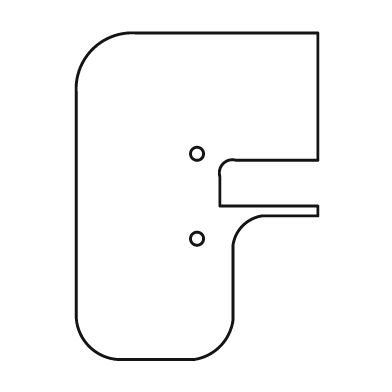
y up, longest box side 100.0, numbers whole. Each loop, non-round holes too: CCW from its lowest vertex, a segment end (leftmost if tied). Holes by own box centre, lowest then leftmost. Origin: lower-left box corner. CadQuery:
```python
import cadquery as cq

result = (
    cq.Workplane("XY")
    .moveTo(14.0, 0.0)
    .lineTo(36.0, 0.0)
    .threePointArc((44.0, 4.0), (48.0, 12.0))
    .lineTo(48.0, 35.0)
    .threePointArc((51.0, 41.0), (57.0, 44.0))
    .lineTo(74.0, 44.0)
    .lineTo(74.0, 47.0)
    .lineTo(44.0, 47.0)
    .lineTo(44.0, 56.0)
    .threePointArc((45.0, 60.0), (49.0, 61.0))
    .lineTo(74.0, 61.0)
    .lineTo(74.0, 100.0)
    .lineTo(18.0, 100.0)
    .threePointArc((5.0, 95.0), (0.0, 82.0))
    .lineTo(0.0, 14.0)
    .threePointArc((4.0, 4.0), (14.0, 0.0))
    .close()
    .moveTo(37.0, 37.0)
    .circle(2.0)
    .moveTo(37.0, 63.0)
    .circle(2.0)
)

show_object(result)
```